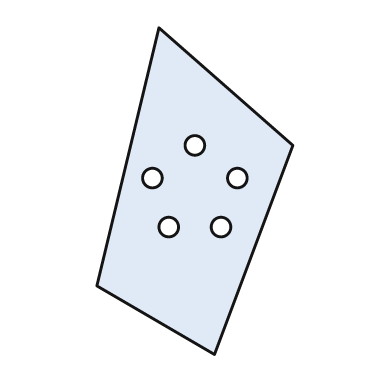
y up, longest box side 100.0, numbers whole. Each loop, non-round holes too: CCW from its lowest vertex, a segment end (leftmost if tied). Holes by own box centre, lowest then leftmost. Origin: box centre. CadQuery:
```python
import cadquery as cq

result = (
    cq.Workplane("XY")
    .moveTo(6.0, -50.0)
    .lineTo(30.0, 14.0)
    .lineTo(-11.0, 50.0)
    .lineTo(-30.0, -29.0)
    .close()
    .moveTo(-8.0, -11.0)
    .circle(3.0)
    .moveTo(8.0, -11.0)
    .circle(3.0)
    .moveTo(-13.0, 4.0)
    .circle(3.0)
    .moveTo(13.0, 4.0)
    .circle(3.0)
    .moveTo(0.0, 14.0)
    .circle(3.0)
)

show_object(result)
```